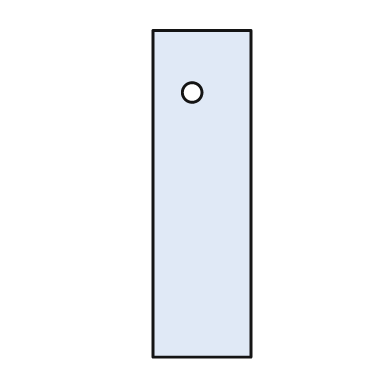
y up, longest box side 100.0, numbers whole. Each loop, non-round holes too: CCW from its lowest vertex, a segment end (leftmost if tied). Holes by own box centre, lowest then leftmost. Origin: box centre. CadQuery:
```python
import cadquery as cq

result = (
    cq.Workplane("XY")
    .moveTo(-15.0, -50.0)
    .lineTo(15.0, -50.0)
    .lineTo(15.0, 50.0)
    .lineTo(-15.0, 50.0)
    .close()
    .moveTo(-3.0, 31.0)
    .circle(3.0)
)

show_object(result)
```